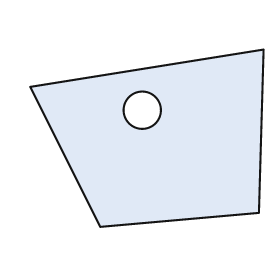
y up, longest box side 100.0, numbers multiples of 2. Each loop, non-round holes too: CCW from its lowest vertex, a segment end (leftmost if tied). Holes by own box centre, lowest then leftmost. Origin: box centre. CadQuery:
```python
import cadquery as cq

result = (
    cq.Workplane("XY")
    .moveTo(-20.0, -38.0)
    .lineTo(48.0, -32.0)
    .lineTo(50.0, 38.0)
    .lineTo(-50.0, 22.0)
    .close()
    .moveTo(-2.0, 12.0)
    .circle(8.0)
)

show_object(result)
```